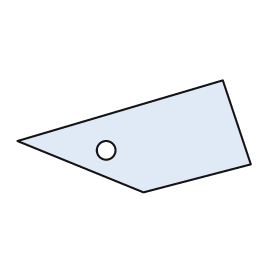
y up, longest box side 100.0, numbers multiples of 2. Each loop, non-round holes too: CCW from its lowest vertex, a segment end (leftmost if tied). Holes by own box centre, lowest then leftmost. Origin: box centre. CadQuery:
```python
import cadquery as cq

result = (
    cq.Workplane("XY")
    .moveTo(4.0, -24.0)
    .lineTo(50.0, -12.0)
    .lineTo(38.0, 24.0)
    .lineTo(-50.0, -2.0)
    .close()
    .moveTo(-12.0, -6.0)
    .circle(4.0)
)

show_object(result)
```